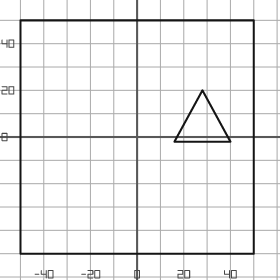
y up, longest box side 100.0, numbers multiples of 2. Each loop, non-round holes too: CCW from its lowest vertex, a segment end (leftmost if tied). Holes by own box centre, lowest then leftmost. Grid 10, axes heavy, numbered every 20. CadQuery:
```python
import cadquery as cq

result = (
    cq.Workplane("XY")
    .moveTo(-50.0, -50.0)
    .lineTo(50.0, -50.0)
    .lineTo(50.0, 50.0)
    .lineTo(-50.0, 50.0)
    .close()
    .moveTo(16.0, -2.0)
    .lineTo(40.0, -2.0)
    .lineTo(28.0, 20.0)
    .close()
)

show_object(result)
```